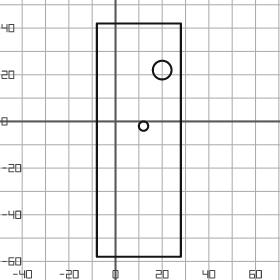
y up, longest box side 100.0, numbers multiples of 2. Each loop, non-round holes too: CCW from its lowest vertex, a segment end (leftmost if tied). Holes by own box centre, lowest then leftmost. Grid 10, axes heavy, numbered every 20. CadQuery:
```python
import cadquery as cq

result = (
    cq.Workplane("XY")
    .moveTo(-8.0, -58.0)
    .lineTo(28.0, -58.0)
    .lineTo(28.0, 42.0)
    .lineTo(-8.0, 42.0)
    .close()
    .moveTo(12.0, -2.0)
    .circle(2.0)
    .moveTo(20.0, 22.0)
    .circle(4.0)
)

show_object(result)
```